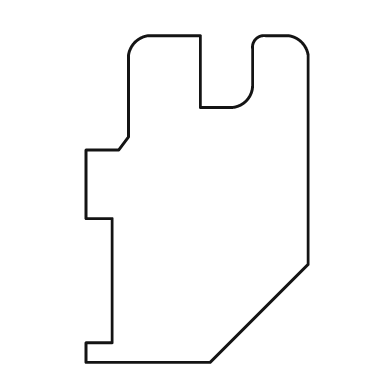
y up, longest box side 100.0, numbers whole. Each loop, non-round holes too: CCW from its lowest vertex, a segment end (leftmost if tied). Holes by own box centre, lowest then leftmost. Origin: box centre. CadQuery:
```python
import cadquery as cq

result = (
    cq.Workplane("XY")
    .moveTo(-34.0, -50.0)
    .lineTo(4.0, -50.0)
    .lineTo(34.0, -20.0)
    .lineTo(34.0, 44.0)
    .threePointArc((32.0, 48.0), (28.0, 50.0))
    .lineTo(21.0, 50.0)
    .threePointArc((18.0, 49.0), (17.0, 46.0))
    .lineTo(17.0, 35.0)
    .threePointArc((15.0, 30.0), (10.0, 28.0))
    .lineTo(1.0, 28.0)
    .lineTo(1.0, 50.0)
    .lineTo(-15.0, 50.0)
    .threePointArc((-19.0, 48.0), (-21.0, 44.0))
    .lineTo(-21.0, 19.0)
    .lineTo(-24.0, 15.0)
    .lineTo(-34.0, 15.0)
    .lineTo(-34.0, -6.0)
    .lineTo(-26.0, -6.0)
    .lineTo(-26.0, -44.0)
    .lineTo(-34.0, -44.0)
    .close()
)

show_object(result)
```